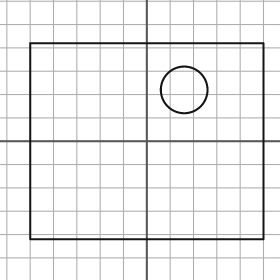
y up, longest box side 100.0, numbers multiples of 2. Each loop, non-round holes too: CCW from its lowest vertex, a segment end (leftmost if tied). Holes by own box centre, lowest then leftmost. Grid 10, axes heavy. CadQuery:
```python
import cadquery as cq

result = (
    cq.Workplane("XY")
    .moveTo(-50.0, -42.0)
    .lineTo(50.0, -42.0)
    .lineTo(50.0, 42.0)
    .lineTo(-50.0, 42.0)
    .close()
    .moveTo(16.0, 22.0)
    .circle(10.0)
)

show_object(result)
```